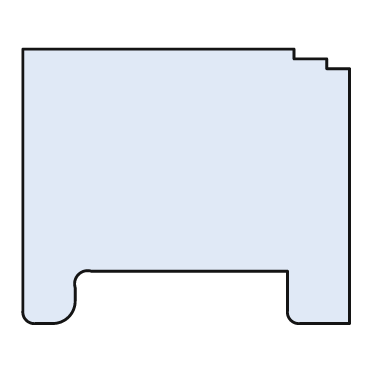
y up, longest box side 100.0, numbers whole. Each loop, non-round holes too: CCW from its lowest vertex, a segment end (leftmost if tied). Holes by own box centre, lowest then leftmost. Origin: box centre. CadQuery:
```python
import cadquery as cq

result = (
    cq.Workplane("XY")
    .moveTo(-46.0, -42.0)
    .lineTo(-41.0, -42.0)
    .threePointArc((-36.0, -40.0), (-34.0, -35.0))
    .lineTo(-34.0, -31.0)
    .threePointArc((-33.0, -27.0), (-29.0, -26.0))
    .lineTo(31.0, -26.0)
    .lineTo(31.0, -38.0)
    .threePointArc((32.0, -41.0), (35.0, -42.0))
    .lineTo(50.0, -42.0)
    .lineTo(50.0, 36.0)
    .lineTo(43.0, 36.0)
    .lineTo(43.0, 39.0)
    .lineTo(33.0, 39.0)
    .lineTo(33.0, 42.0)
    .lineTo(-50.0, 42.0)
    .lineTo(-50.0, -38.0)
    .threePointArc((-49.0, -41.0), (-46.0, -42.0))
    .close()
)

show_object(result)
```